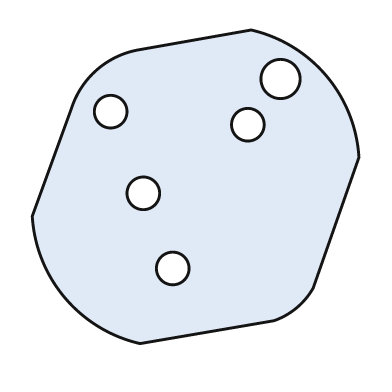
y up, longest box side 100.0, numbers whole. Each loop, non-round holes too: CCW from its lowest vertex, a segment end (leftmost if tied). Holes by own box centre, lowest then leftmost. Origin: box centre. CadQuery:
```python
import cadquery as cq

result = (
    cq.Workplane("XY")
    .moveTo(-17.0, -48.0)
    .lineTo(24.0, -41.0)
    .threePointArc((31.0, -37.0), (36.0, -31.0))
    .lineTo(50.0, 9.0)
    .threePointArc((40.0, 34.0), (17.0, 48.0))
    .lineTo(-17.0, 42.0)
    .threePointArc((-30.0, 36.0), (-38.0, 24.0))
    .lineTo(-50.0, -9.0)
    .threePointArc((-40.0, -34.0), (-17.0, -48.0))
    .close()
    .moveTo(-7.0, -25.0)
    .circle(5.0)
    .moveTo(-16.0, -2.0)
    .circle(5.0)
    .moveTo(16.0, 19.0)
    .circle(5.0)
    .moveTo(-26.0, 23.0)
    .circle(5.0)
    .moveTo(26.0, 33.0)
    .circle(6.0)
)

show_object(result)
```